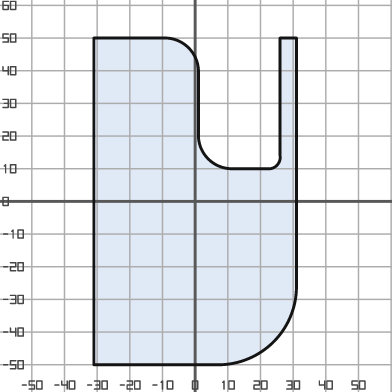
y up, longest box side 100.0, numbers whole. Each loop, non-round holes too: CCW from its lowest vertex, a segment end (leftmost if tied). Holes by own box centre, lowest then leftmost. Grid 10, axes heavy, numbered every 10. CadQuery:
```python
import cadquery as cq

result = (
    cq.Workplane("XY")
    .moveTo(-31.0, -50.0)
    .lineTo(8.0, -50.0)
    .threePointArc((24.0, -43.0), (31.0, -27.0))
    .lineTo(31.0, 50.0)
    .lineTo(26.0, 50.0)
    .lineTo(26.0, 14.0)
    .threePointArc((25.0, 11.0), (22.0, 10.0))
    .lineTo(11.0, 10.0)
    .threePointArc((4.0, 13.0), (1.0, 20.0))
    .lineTo(1.0, 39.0)
    .threePointArc((-2.0, 47.0), (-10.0, 50.0))
    .lineTo(-31.0, 50.0)
    .close()
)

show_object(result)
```